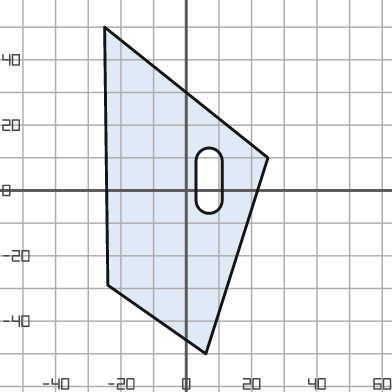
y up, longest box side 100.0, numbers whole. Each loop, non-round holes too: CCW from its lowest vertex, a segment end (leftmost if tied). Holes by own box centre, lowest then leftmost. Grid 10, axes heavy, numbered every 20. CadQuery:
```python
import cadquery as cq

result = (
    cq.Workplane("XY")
    .moveTo(6.0, -50.0)
    .lineTo(25.0, 10.0)
    .lineTo(-25.0, 50.0)
    .lineTo(-24.0, -29.0)
    .close()
    .moveTo(3.0, -3.0)
    .threePointArc((7.0, -7.0), (11.0, -3.0))
    .lineTo(11.0, 9.0)
    .threePointArc((7.0, 13.0), (3.0, 9.0))
    .close()
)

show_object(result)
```